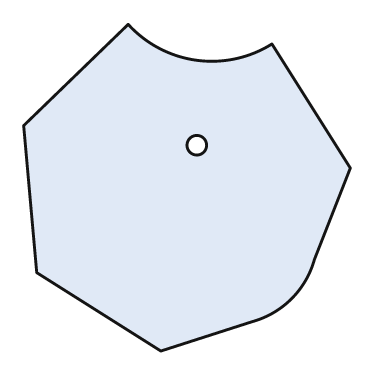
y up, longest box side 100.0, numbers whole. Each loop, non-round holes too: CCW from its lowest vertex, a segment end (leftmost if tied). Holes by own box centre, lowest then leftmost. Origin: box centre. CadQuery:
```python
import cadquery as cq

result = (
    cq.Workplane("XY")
    .moveTo(-8.0, -50.0)
    .lineTo(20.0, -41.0)
    .threePointArc((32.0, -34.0), (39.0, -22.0))
    .lineTo(50.0, 6.0)
    .lineTo(26.0, 44.0)
    .threePointArc((3.0, 39.0), (-18.0, 50.0))
    .lineTo(-50.0, 19.0)
    .lineTo(-46.0, -26.0)
    .close()
    .moveTo(3.0, 13.0)
    .circle(3.0)
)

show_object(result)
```